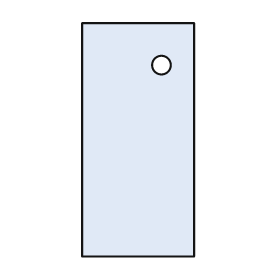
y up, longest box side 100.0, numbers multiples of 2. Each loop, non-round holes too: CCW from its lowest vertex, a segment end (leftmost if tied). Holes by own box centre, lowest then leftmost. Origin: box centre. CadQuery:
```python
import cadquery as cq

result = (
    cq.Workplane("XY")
    .moveTo(-24.0, -50.0)
    .lineTo(24.0, -50.0)
    .lineTo(24.0, 50.0)
    .lineTo(-24.0, 50.0)
    .close()
    .moveTo(10.0, 32.0)
    .circle(4.0)
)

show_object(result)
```